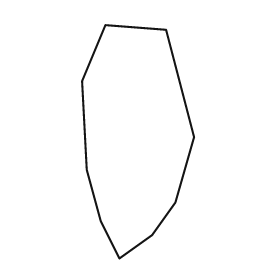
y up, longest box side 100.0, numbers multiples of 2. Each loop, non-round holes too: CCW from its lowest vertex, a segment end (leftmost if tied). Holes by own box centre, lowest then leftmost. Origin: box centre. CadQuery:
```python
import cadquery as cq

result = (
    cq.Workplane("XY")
    .moveTo(-8.0, -50.0)
    .lineTo(6.0, -40.0)
    .lineTo(16.0, -26.0)
    .lineTo(24.0, 2.0)
    .lineTo(12.0, 48.0)
    .lineTo(-14.0, 50.0)
    .lineTo(-24.0, 26.0)
    .lineTo(-22.0, -12.0)
    .lineTo(-16.0, -34.0)
    .close()
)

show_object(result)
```